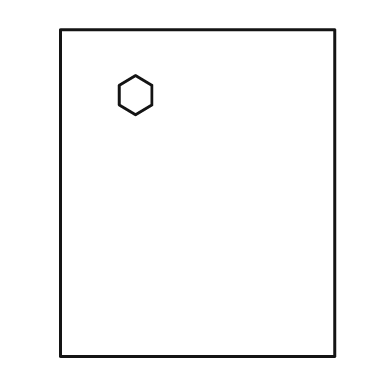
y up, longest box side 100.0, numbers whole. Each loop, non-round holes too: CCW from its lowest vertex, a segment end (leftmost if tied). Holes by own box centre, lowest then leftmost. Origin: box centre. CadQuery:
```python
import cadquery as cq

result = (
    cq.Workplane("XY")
    .moveTo(-42.0, -50.0)
    .lineTo(42.0, -50.0)
    .lineTo(42.0, 50.0)
    .lineTo(-42.0, 50.0)
    .close()
    .moveTo(-19.0, 24.0)
    .lineTo(-14.0, 27.0)
    .lineTo(-14.0, 33.0)
    .lineTo(-19.0, 36.0)
    .lineTo(-24.0, 33.0)
    .lineTo(-24.0, 27.0)
    .close()
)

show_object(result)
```